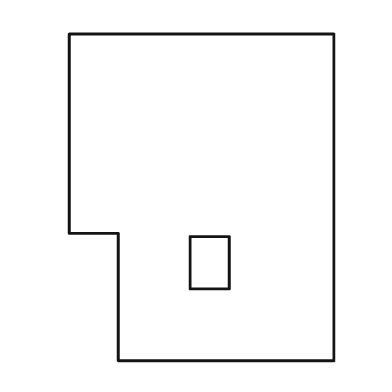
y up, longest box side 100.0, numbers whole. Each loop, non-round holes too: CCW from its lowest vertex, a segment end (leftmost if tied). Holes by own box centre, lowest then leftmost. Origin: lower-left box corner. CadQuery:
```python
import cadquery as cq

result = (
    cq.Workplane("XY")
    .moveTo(15.0, 0.0)
    .lineTo(81.0, 0.0)
    .lineTo(81.0, 100.0)
    .lineTo(0.0, 100.0)
    .lineTo(0.0, 39.0)
    .lineTo(15.0, 39.0)
    .close()
    .moveTo(37.0, 22.0)
    .lineTo(49.0, 22.0)
    .lineTo(49.0, 38.0)
    .lineTo(37.0, 38.0)
    .close()
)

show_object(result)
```